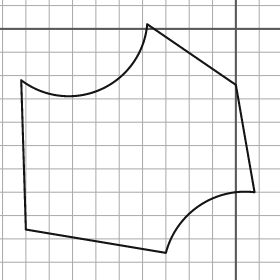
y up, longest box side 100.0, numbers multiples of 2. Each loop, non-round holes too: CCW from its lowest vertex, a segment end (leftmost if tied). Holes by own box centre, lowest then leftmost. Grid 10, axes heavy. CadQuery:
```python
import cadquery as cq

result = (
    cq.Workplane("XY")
    .moveTo(-30.0, -96.0)
    .threePointArc((-16.0, -76.0), (8.0, -70.0))
    .lineTo(0.0, -24.0)
    .lineTo(-38.0, 2.0)
    .threePointArc((-58.0, -26.0), (-92.0, -22.0))
    .lineTo(-90.0, -86.0)
    .close()
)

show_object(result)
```